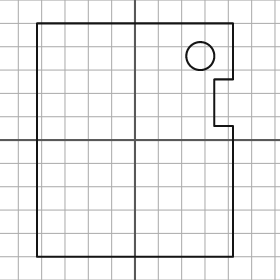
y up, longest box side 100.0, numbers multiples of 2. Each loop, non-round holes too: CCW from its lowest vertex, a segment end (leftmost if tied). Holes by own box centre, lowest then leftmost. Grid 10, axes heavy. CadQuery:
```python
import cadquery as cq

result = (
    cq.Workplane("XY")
    .moveTo(-42.0, -50.0)
    .lineTo(42.0, -50.0)
    .lineTo(42.0, 6.0)
    .lineTo(34.0, 6.0)
    .lineTo(34.0, 26.0)
    .lineTo(42.0, 26.0)
    .lineTo(42.0, 50.0)
    .lineTo(-42.0, 50.0)
    .close()
    .moveTo(28.0, 36.0)
    .circle(6.0)
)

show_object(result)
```